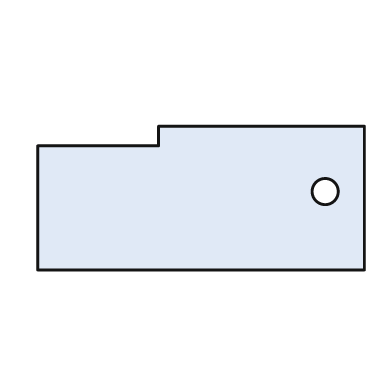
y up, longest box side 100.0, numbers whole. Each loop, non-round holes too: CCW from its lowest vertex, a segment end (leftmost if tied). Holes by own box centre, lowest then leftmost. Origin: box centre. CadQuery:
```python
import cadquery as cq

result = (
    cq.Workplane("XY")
    .moveTo(-50.0, -22.0)
    .lineTo(50.0, -22.0)
    .lineTo(50.0, 22.0)
    .lineTo(-13.0, 22.0)
    .lineTo(-13.0, 16.0)
    .lineTo(-50.0, 16.0)
    .close()
    .moveTo(38.0, 2.0)
    .circle(4.0)
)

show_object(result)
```